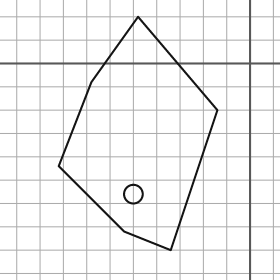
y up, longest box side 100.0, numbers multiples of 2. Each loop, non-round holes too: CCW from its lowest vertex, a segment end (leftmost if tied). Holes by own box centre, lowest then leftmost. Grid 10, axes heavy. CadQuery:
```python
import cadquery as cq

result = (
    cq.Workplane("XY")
    .moveTo(-34.0, -80.0)
    .lineTo(-14.0, -20.0)
    .lineTo(-48.0, 20.0)
    .lineTo(-68.0, -8.0)
    .lineTo(-82.0, -44.0)
    .lineTo(-54.0, -72.0)
    .close()
    .moveTo(-50.0, -56.0)
    .circle(4.0)
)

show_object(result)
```